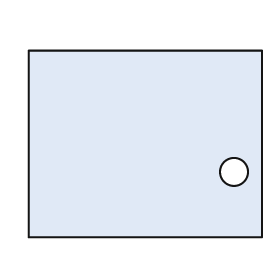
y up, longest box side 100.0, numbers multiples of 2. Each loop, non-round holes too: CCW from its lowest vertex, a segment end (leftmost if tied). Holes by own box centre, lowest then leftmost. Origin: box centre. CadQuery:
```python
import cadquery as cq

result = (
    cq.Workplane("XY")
    .moveTo(-50.0, -40.0)
    .lineTo(50.0, -40.0)
    .lineTo(50.0, 40.0)
    .lineTo(-50.0, 40.0)
    .close()
    .moveTo(38.0, -12.0)
    .circle(6.0)
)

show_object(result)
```